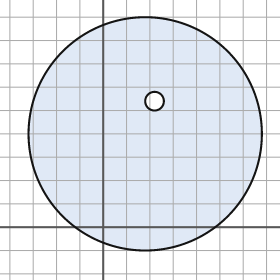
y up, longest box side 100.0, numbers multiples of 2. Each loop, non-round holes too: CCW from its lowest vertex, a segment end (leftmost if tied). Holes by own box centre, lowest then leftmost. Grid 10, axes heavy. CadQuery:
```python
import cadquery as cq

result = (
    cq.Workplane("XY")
    .moveTo(18.0, 40.0)
    .circle(50.0)
    .moveTo(22.0, 54.0)
    .circle(4.0)
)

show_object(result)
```